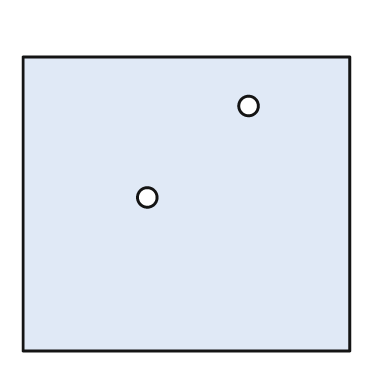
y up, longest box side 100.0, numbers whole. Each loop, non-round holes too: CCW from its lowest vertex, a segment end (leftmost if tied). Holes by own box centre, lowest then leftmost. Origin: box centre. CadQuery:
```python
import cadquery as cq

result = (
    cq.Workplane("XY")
    .moveTo(-50.0, -45.0)
    .lineTo(50.0, -45.0)
    .lineTo(50.0, 45.0)
    .lineTo(-50.0, 45.0)
    .close()
    .moveTo(-12.0, 2.0)
    .circle(3.0)
    .moveTo(19.0, 30.0)
    .circle(3.0)
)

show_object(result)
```